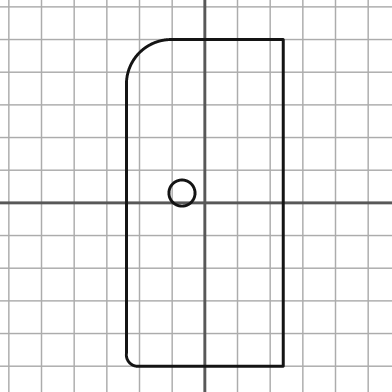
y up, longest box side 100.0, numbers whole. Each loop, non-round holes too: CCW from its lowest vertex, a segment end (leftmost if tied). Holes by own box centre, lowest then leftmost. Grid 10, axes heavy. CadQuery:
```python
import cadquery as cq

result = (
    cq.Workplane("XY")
    .moveTo(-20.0, -50.0)
    .lineTo(24.0, -50.0)
    .lineTo(24.0, 50.0)
    .lineTo(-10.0, 50.0)
    .threePointArc((-20.0, 46.0), (-24.0, 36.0))
    .lineTo(-24.0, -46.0)
    .threePointArc((-23.0, -49.0), (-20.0, -50.0))
    .close()
    .moveTo(-7.0, 3.0)
    .circle(4.0)
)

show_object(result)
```